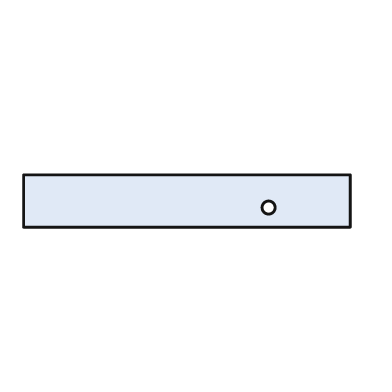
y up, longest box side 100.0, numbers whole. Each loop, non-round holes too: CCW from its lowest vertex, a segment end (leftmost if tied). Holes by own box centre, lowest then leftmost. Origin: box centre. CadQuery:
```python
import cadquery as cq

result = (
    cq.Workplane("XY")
    .moveTo(-50.0, -8.0)
    .lineTo(50.0, -8.0)
    .lineTo(50.0, 8.0)
    .lineTo(-50.0, 8.0)
    .close()
    .moveTo(25.0, -2.0)
    .circle(2.0)
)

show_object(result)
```